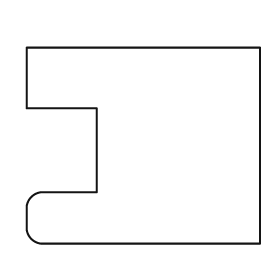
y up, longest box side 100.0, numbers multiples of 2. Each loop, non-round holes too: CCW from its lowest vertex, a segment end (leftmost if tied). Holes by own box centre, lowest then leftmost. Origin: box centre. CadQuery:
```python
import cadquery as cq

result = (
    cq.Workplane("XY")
    .moveTo(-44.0, -42.0)
    .lineTo(50.0, -42.0)
    .lineTo(50.0, 42.0)
    .lineTo(-50.0, 42.0)
    .lineTo(-50.0, 16.0)
    .lineTo(-20.0, 16.0)
    .lineTo(-20.0, -20.0)
    .lineTo(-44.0, -20.0)
    .threePointArc((-48.0, -22.0), (-50.0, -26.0))
    .lineTo(-50.0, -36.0)
    .threePointArc((-48.0, -40.0), (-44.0, -42.0))
    .close()
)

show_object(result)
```